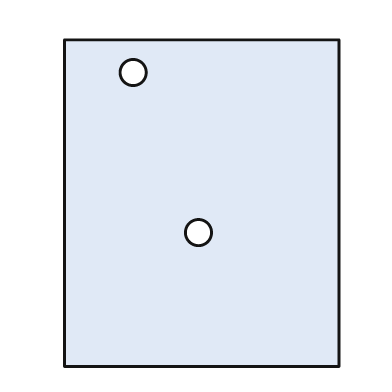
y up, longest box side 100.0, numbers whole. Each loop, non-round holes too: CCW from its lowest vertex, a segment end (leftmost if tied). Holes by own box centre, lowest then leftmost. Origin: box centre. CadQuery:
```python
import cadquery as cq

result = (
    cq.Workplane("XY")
    .moveTo(-42.0, -50.0)
    .lineTo(42.0, -50.0)
    .lineTo(42.0, 50.0)
    .lineTo(-42.0, 50.0)
    .close()
    .moveTo(-1.0, -9.0)
    .circle(4.0)
    .moveTo(-21.0, 40.0)
    .circle(4.0)
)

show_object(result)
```